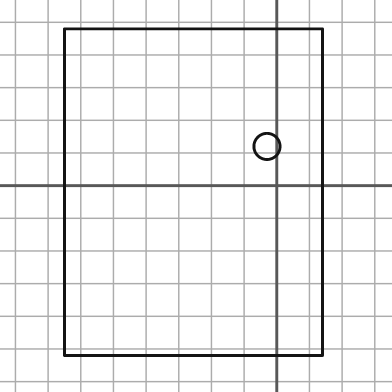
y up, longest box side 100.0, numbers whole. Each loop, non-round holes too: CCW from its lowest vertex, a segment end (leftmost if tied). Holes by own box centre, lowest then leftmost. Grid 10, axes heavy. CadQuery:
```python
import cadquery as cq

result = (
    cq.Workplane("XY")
    .moveTo(-65.0, -52.0)
    .lineTo(14.0, -52.0)
    .lineTo(14.0, 48.0)
    .lineTo(-65.0, 48.0)
    .close()
    .moveTo(-3.0, 12.0)
    .circle(4.0)
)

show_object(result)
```